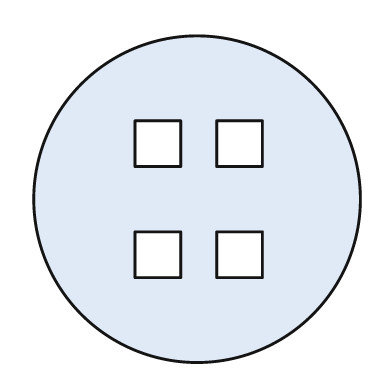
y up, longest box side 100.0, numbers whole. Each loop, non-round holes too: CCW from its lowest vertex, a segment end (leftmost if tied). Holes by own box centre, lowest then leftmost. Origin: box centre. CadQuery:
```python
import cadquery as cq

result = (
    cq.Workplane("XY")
    .moveTo(0.0, 0.0)
    .circle(50.0)
    .moveTo(-19.0, -24.0)
    .lineTo(-5.0, -24.0)
    .lineTo(-5.0, -10.0)
    .lineTo(-19.0, -10.0)
    .close()
    .moveTo(6.0, -24.0)
    .lineTo(20.0, -24.0)
    .lineTo(20.0, -10.0)
    .lineTo(6.0, -10.0)
    .close()
    .moveTo(-19.0, 10.0)
    .lineTo(-5.0, 10.0)
    .lineTo(-5.0, 24.0)
    .lineTo(-19.0, 24.0)
    .close()
    .moveTo(6.0, 10.0)
    .lineTo(20.0, 10.0)
    .lineTo(20.0, 24.0)
    .lineTo(6.0, 24.0)
    .close()
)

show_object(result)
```